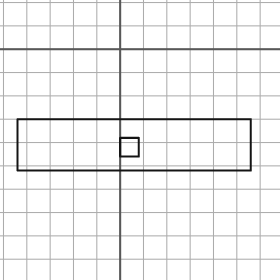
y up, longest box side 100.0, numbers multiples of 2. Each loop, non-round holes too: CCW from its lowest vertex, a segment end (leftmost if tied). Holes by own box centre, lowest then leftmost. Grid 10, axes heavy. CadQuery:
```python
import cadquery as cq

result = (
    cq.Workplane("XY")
    .moveTo(-44.0, -52.0)
    .lineTo(56.0, -52.0)
    .lineTo(56.0, -30.0)
    .lineTo(-44.0, -30.0)
    .close()
    .moveTo(0.0, -46.0)
    .lineTo(8.0, -46.0)
    .lineTo(8.0, -38.0)
    .lineTo(0.0, -38.0)
    .close()
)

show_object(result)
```